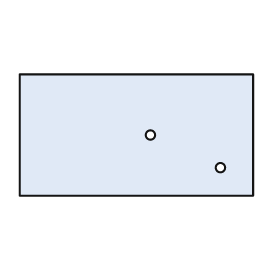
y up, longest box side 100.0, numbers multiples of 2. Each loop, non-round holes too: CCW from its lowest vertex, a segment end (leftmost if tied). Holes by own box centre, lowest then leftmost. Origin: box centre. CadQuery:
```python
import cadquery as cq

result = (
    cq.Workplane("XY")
    .moveTo(-50.0, -26.0)
    .lineTo(50.0, -26.0)
    .lineTo(50.0, 26.0)
    .lineTo(-50.0, 26.0)
    .close()
    .moveTo(36.0, -14.0)
    .circle(2.0)
    .moveTo(6.0, 0.0)
    .circle(2.0)
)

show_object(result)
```